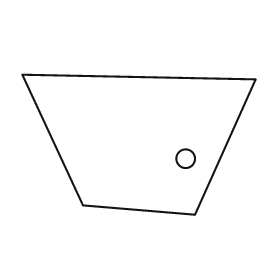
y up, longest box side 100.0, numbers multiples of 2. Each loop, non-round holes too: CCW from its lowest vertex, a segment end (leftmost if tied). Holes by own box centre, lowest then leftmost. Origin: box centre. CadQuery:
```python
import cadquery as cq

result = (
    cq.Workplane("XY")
    .moveTo(24.0, -30.0)
    .lineTo(50.0, 28.0)
    .lineTo(-50.0, 30.0)
    .lineTo(-24.0, -26.0)
    .close()
    .moveTo(20.0, -6.0)
    .circle(4.0)
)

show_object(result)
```